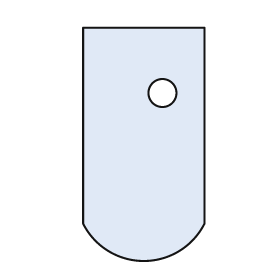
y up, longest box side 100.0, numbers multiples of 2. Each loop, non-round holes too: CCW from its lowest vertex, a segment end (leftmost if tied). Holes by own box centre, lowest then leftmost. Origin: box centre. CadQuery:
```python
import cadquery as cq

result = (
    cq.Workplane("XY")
    .moveTo(-26.0, -34.0)
    .threePointArc((0.0, -50.0), (26.0, -34.0))
    .lineTo(26.0, 50.0)
    .lineTo(-26.0, 50.0)
    .close()
    .moveTo(8.0, 22.0)
    .circle(6.0)
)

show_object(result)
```